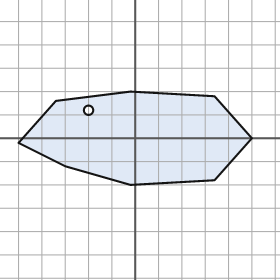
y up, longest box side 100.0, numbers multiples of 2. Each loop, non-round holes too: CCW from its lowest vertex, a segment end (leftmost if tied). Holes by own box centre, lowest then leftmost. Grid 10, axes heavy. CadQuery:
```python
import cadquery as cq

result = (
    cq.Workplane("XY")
    .moveTo(-2.0, -20.0)
    .lineTo(34.0, -18.0)
    .lineTo(50.0, 0.0)
    .lineTo(34.0, 18.0)
    .lineTo(-2.0, 20.0)
    .lineTo(-34.0, 16.0)
    .lineTo(-50.0, -2.0)
    .lineTo(-30.0, -12.0)
    .close()
    .moveTo(-20.0, 12.0)
    .circle(2.0)
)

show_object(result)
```